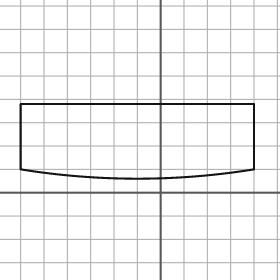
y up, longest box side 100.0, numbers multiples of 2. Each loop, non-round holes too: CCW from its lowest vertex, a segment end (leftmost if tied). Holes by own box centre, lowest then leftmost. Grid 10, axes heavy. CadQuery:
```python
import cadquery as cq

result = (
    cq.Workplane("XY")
    .moveTo(-60.0, 10.0)
    .threePointArc((-10.0, 6.0), (40.0, 10.0))
    .lineTo(40.0, 38.0)
    .lineTo(-60.0, 38.0)
    .close()
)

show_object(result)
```